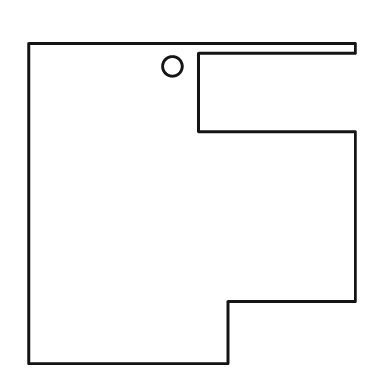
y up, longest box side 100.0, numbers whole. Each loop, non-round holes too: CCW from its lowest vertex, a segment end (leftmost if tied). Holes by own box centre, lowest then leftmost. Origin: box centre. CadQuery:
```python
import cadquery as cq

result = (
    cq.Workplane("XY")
    .moveTo(-50.0, -49.0)
    .lineTo(11.0, -49.0)
    .lineTo(11.0, -30.0)
    .lineTo(50.0, -30.0)
    .lineTo(50.0, 22.0)
    .lineTo(2.0, 22.0)
    .lineTo(2.0, 46.0)
    .lineTo(50.0, 46.0)
    .lineTo(50.0, 49.0)
    .lineTo(-50.0, 49.0)
    .close()
    .moveTo(-6.0, 42.0)
    .circle(3.0)
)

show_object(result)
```